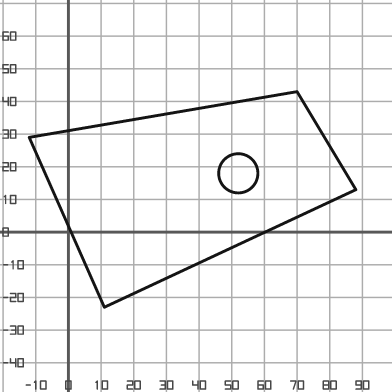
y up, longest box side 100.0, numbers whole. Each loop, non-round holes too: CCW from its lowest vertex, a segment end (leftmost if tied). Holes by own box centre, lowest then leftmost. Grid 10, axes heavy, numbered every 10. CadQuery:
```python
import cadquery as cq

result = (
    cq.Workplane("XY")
    .moveTo(11.0, -23.0)
    .lineTo(88.0, 13.0)
    .lineTo(70.0, 43.0)
    .lineTo(-12.0, 29.0)
    .close()
    .moveTo(52.0, 18.0)
    .circle(6.0)
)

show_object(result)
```